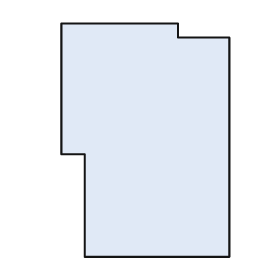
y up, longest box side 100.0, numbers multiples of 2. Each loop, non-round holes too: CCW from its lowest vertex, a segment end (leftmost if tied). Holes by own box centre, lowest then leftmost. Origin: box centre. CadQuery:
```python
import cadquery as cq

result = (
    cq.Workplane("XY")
    .moveTo(-26.0, -50.0)
    .lineTo(36.0, -50.0)
    .lineTo(36.0, 44.0)
    .lineTo(14.0, 44.0)
    .lineTo(14.0, 50.0)
    .lineTo(-36.0, 50.0)
    .lineTo(-36.0, -6.0)
    .lineTo(-26.0, -6.0)
    .close()
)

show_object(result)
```